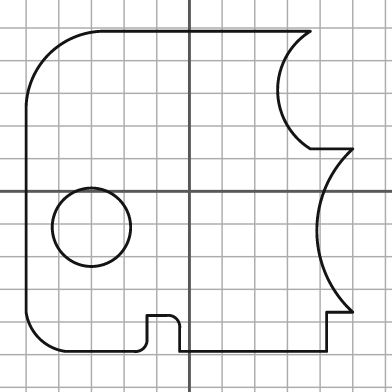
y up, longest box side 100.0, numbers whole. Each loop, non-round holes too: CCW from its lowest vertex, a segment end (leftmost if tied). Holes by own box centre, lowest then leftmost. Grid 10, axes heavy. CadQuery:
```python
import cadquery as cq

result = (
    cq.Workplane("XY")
    .moveTo(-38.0, -49.0)
    .lineTo(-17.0, -49.0)
    .threePointArc((-14.0, -48.0), (-13.0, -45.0))
    .lineTo(-13.0, -38.0)
    .lineTo(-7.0, -38.0)
    .threePointArc((-4.0, -39.0), (-3.0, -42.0))
    .lineTo(-3.0, -49.0)
    .lineTo(42.0, -49.0)
    .lineTo(42.0, -37.0)
    .lineTo(50.0, -37.0)
    .threePointArc((39.0, -12.0), (50.0, 13.0))
    .lineTo(37.0, 13.0)
    .threePointArc((27.0, 31.0), (37.0, 49.0))
    .lineTo(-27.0, 49.0)
    .threePointArc((-43.0, 42.0), (-50.0, 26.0))
    .lineTo(-50.0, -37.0)
    .threePointArc((-46.0, -45.0), (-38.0, -49.0))
    .close()
    .moveTo(-30.0, -11.0)
    .circle(12.0)
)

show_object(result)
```